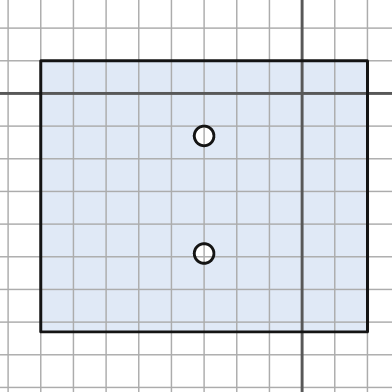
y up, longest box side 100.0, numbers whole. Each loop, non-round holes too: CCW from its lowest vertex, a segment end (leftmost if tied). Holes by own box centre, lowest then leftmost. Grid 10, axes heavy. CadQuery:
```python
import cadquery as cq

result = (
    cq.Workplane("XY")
    .moveTo(-80.0, -73.0)
    .lineTo(20.0, -73.0)
    .lineTo(20.0, 10.0)
    .lineTo(-80.0, 10.0)
    .close()
    .moveTo(-30.0, -49.0)
    .circle(3.0)
    .moveTo(-30.0, -13.0)
    .circle(3.0)
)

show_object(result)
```